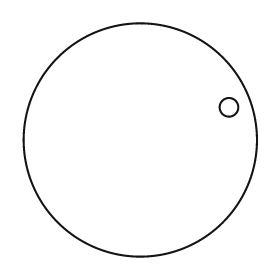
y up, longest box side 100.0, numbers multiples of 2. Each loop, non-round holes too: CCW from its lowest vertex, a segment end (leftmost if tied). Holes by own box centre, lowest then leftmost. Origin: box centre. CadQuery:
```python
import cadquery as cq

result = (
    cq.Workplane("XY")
    .moveTo(0.0, 0.0)
    .circle(50.0)
    .moveTo(38.0, 14.0)
    .circle(4.0)
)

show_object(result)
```